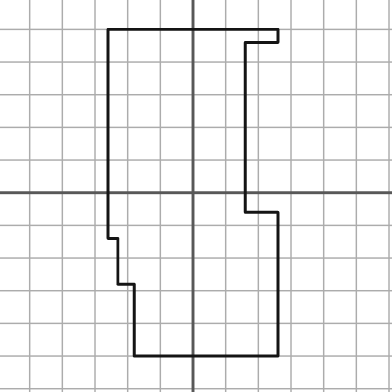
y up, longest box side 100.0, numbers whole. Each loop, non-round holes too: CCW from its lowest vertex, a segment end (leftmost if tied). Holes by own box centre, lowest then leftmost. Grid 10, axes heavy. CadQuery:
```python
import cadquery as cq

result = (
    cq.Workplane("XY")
    .moveTo(-18.0, -50.0)
    .lineTo(26.0, -50.0)
    .lineTo(26.0, -6.0)
    .lineTo(16.0, -6.0)
    .lineTo(16.0, 46.0)
    .lineTo(26.0, 46.0)
    .lineTo(26.0, 50.0)
    .lineTo(-26.0, 50.0)
    .lineTo(-26.0, -14.0)
    .lineTo(-23.0, -14.0)
    .lineTo(-23.0, -28.0)
    .lineTo(-18.0, -28.0)
    .close()
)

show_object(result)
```